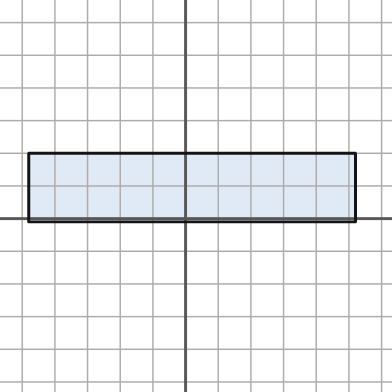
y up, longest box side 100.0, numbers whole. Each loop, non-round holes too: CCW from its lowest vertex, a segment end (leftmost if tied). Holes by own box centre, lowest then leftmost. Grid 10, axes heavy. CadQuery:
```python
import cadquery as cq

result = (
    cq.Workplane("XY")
    .moveTo(-48.0, -1.0)
    .lineTo(52.0, -1.0)
    .lineTo(52.0, 20.0)
    .lineTo(-48.0, 20.0)
    .close()
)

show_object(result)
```